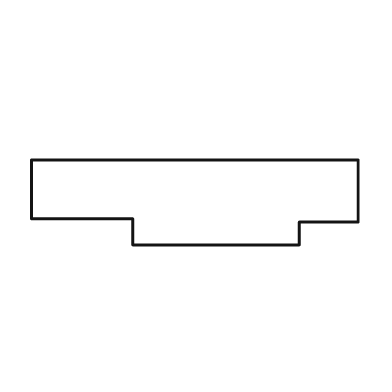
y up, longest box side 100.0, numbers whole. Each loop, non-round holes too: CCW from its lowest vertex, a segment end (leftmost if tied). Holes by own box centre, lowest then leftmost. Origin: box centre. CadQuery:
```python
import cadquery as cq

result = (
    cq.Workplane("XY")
    .moveTo(-19.0, -13.0)
    .lineTo(32.0, -13.0)
    .lineTo(32.0, -6.0)
    .lineTo(50.0, -6.0)
    .lineTo(50.0, 13.0)
    .lineTo(-50.0, 13.0)
    .lineTo(-50.0, -5.0)
    .lineTo(-19.0, -5.0)
    .close()
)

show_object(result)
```